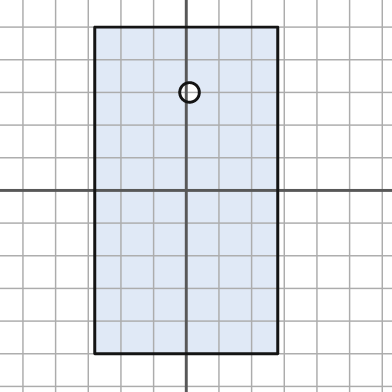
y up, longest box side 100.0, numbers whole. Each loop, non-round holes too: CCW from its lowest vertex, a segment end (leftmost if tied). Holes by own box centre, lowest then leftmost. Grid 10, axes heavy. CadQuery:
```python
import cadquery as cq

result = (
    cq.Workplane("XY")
    .moveTo(-28.0, -50.0)
    .lineTo(28.0, -50.0)
    .lineTo(28.0, 50.0)
    .lineTo(-28.0, 50.0)
    .close()
    .moveTo(1.0, 30.0)
    .circle(3.0)
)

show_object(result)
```